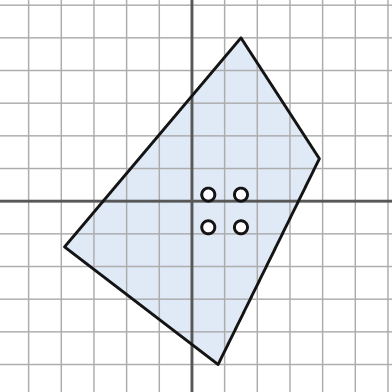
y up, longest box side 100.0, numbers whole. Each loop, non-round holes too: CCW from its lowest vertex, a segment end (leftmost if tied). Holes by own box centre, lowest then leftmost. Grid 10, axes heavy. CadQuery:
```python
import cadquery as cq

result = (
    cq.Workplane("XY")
    .moveTo(8.0, -50.0)
    .lineTo(39.0, 13.0)
    .lineTo(15.0, 50.0)
    .lineTo(-39.0, -14.0)
    .close()
    .moveTo(5.0, -8.0)
    .circle(2.0)
    .moveTo(15.0, -8.0)
    .circle(2.0)
    .moveTo(5.0, 2.0)
    .circle(2.0)
    .moveTo(15.0, 2.0)
    .circle(2.0)
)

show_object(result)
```